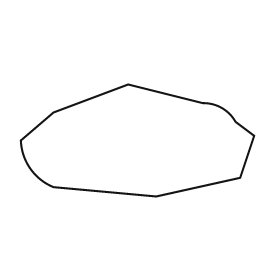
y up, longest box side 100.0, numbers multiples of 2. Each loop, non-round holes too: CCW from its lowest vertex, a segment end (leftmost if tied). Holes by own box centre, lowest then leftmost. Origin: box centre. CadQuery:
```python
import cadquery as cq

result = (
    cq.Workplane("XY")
    .moveTo(8.0, -24.0)
    .lineTo(44.0, -16.0)
    .lineTo(50.0, 2.0)
    .lineTo(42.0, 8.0)
    .threePointArc((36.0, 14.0), (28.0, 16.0))
    .lineTo(-4.0, 24.0)
    .lineTo(-36.0, 12.0)
    .lineTo(-50.0, 0.0)
    .threePointArc((-46.0, -12.0), (-36.0, -20.0))
    .close()
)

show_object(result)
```